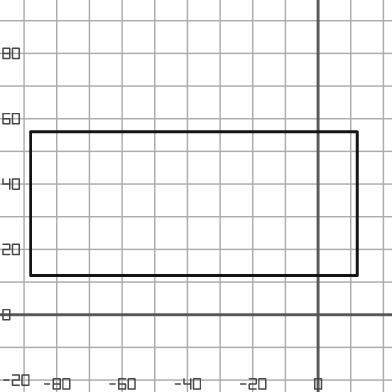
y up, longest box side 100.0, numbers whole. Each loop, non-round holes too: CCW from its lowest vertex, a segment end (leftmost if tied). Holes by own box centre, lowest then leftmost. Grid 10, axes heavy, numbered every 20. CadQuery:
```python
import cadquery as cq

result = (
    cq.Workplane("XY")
    .moveTo(-88.0, 12.0)
    .lineTo(12.0, 12.0)
    .lineTo(12.0, 56.0)
    .lineTo(-88.0, 56.0)
    .close()
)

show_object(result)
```